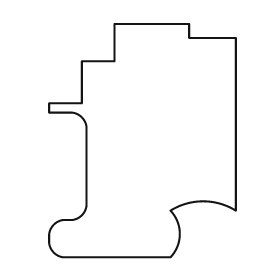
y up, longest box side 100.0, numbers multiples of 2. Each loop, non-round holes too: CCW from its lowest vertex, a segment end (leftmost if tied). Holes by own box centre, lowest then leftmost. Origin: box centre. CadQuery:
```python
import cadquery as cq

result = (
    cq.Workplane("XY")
    .moveTo(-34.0, -50.0)
    .lineTo(12.0, -50.0)
    .threePointArc((16.0, -40.0), (12.0, -30.0))
    .threePointArc((26.0, -26.0), (40.0, -30.0))
    .lineTo(40.0, 44.0)
    .lineTo(20.0, 44.0)
    .lineTo(20.0, 50.0)
    .lineTo(-12.0, 50.0)
    .lineTo(-12.0, 34.0)
    .lineTo(-26.0, 34.0)
    .lineTo(-26.0, 16.0)
    .lineTo(-40.0, 16.0)
    .lineTo(-40.0, 12.0)
    .lineTo(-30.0, 12.0)
    .threePointArc((-26.0, 10.0), (-24.0, 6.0))
    .lineTo(-24.0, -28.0)
    .threePointArc((-26.0, -32.0), (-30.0, -34.0))
    .lineTo(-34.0, -34.0)
    .threePointArc((-38.0, -36.0), (-40.0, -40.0))
    .lineTo(-40.0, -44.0)
    .threePointArc((-38.0, -48.0), (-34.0, -50.0))
    .close()
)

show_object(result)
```